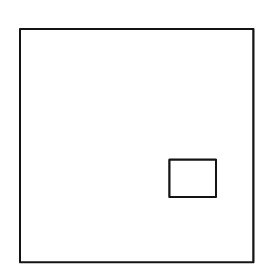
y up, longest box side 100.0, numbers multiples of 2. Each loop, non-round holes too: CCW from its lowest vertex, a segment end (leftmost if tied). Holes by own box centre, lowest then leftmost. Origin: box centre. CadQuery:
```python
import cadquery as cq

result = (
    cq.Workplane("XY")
    .moveTo(-50.0, -50.0)
    .lineTo(50.0, -50.0)
    .lineTo(50.0, 50.0)
    .lineTo(-50.0, 50.0)
    .close()
    .moveTo(14.0, -22.0)
    .lineTo(34.0, -22.0)
    .lineTo(34.0, -6.0)
    .lineTo(14.0, -6.0)
    .close()
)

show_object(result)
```